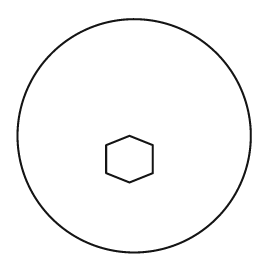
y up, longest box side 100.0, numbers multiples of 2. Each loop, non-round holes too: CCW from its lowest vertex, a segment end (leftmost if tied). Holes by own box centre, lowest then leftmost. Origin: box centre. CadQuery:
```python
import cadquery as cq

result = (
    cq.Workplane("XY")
    .moveTo(0.0, 0.0)
    .circle(50.0)
    .moveTo(-2.0, -20.0)
    .lineTo(8.0, -16.0)
    .lineTo(8.0, -4.0)
    .lineTo(-2.0, 0.0)
    .lineTo(-12.0, -4.0)
    .lineTo(-12.0, -16.0)
    .close()
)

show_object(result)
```